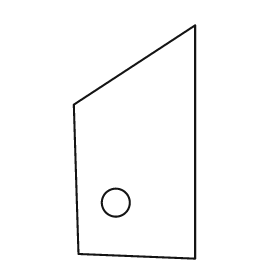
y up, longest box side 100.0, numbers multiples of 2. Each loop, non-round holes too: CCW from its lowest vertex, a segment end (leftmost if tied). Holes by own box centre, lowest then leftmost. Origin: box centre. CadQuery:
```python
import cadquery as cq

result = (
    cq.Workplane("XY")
    .moveTo(26.0, -50.0)
    .lineTo(26.0, 50.0)
    .lineTo(-26.0, 16.0)
    .lineTo(-24.0, -48.0)
    .close()
    .moveTo(-8.0, -26.0)
    .circle(6.0)
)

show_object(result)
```